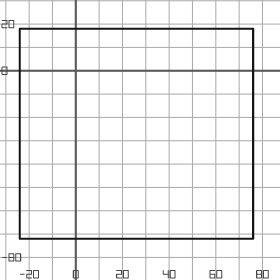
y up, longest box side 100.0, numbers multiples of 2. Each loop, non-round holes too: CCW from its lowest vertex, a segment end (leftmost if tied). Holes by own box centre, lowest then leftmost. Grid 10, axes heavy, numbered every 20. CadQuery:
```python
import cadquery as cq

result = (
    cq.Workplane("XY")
    .moveTo(-24.0, -72.0)
    .lineTo(76.0, -72.0)
    .lineTo(76.0, 18.0)
    .lineTo(-24.0, 18.0)
    .close()
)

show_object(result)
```